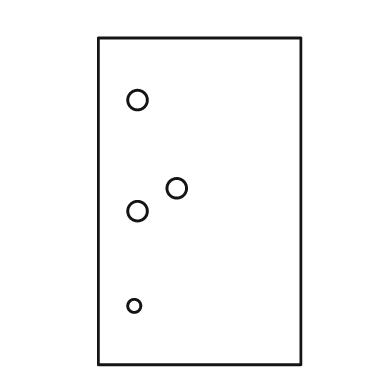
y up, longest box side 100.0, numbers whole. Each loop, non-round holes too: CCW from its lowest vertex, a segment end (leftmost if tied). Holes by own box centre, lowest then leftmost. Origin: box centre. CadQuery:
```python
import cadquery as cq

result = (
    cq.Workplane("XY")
    .moveTo(-31.0, -50.0)
    .lineTo(31.0, -50.0)
    .lineTo(31.0, 50.0)
    .lineTo(-31.0, 50.0)
    .close()
    .moveTo(-20.0, -32.0)
    .circle(2.0)
    .moveTo(-19.0, -3.0)
    .circle(3.0)
    .moveTo(-7.0, 4.0)
    .circle(3.0)
    .moveTo(-19.0, 31.0)
    .circle(3.0)
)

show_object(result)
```